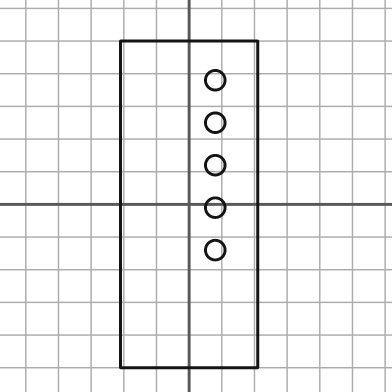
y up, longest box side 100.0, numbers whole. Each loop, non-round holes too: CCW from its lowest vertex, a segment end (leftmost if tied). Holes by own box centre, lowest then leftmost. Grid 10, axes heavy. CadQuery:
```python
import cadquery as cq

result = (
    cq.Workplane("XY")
    .moveTo(-21.0, -50.0)
    .lineTo(21.0, -50.0)
    .lineTo(21.0, 50.0)
    .lineTo(-21.0, 50.0)
    .close()
    .moveTo(8.0, -14.0)
    .circle(3.0)
    .moveTo(8.0, -1.0)
    .circle(3.0)
    .moveTo(8.0, 12.0)
    .circle(3.0)
    .moveTo(8.0, 25.0)
    .circle(3.0)
    .moveTo(8.0, 38.0)
    .circle(3.0)
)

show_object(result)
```